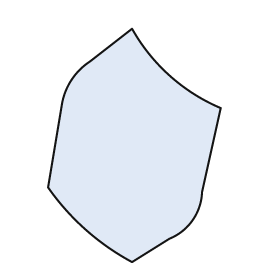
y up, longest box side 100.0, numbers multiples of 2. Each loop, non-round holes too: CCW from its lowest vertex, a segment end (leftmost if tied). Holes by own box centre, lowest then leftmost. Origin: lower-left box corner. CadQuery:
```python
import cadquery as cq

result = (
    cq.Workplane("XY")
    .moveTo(36.0, 0.0)
    .lineTo(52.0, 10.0)
    .threePointArc((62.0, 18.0), (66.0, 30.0))
    .lineTo(74.0, 66.0)
    .threePointArc((52.0, 80.0), (36.0, 100.0))
    .lineTo(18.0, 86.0)
    .threePointArc((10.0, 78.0), (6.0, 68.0))
    .lineTo(0.0, 32.0)
    .threePointArc((16.0, 14.0), (36.0, 0.0))
    .close()
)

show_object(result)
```